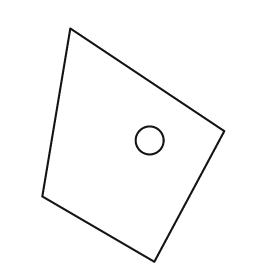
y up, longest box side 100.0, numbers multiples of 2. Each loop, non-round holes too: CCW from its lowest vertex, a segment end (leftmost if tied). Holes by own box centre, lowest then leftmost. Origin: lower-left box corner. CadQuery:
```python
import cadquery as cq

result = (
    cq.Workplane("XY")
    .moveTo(48.0, 0.0)
    .lineTo(78.0, 56.0)
    .lineTo(12.0, 100.0)
    .lineTo(0.0, 28.0)
    .close()
    .moveTo(46.0, 52.0)
    .circle(6.0)
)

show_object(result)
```